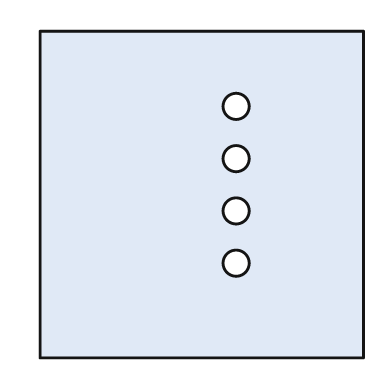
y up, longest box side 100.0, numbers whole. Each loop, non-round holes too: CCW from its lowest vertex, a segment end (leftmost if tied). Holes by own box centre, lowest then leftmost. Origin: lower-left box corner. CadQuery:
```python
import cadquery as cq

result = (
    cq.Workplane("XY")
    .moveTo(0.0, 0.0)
    .lineTo(99.0, 0.0)
    .lineTo(99.0, 100.0)
    .lineTo(0.0, 100.0)
    .close()
    .moveTo(60.0, 29.0)
    .circle(4.0)
    .moveTo(60.0, 45.0)
    .circle(4.0)
    .moveTo(60.0, 61.0)
    .circle(4.0)
    .moveTo(60.0, 77.0)
    .circle(4.0)
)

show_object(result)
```